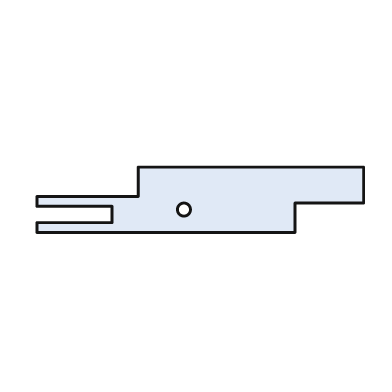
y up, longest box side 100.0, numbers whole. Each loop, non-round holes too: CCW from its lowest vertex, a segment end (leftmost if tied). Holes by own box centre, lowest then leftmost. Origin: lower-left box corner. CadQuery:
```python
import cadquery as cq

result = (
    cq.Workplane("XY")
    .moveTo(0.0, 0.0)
    .lineTo(79.0, 0.0)
    .lineTo(79.0, 9.0)
    .lineTo(100.0, 9.0)
    .lineTo(100.0, 20.0)
    .lineTo(31.0, 20.0)
    .lineTo(31.0, 11.0)
    .lineTo(0.0, 11.0)
    .lineTo(0.0, 8.0)
    .lineTo(23.0, 8.0)
    .lineTo(23.0, 3.0)
    .lineTo(0.0, 3.0)
    .close()
    .moveTo(45.0, 7.0)
    .circle(2.0)
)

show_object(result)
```